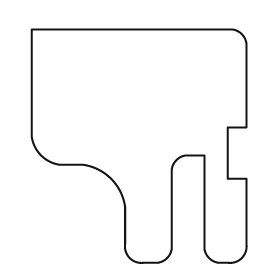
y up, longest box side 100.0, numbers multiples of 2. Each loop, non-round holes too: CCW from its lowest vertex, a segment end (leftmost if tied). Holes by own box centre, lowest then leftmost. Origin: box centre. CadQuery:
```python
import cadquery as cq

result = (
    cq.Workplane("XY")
    .moveTo(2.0, -50.0)
    .lineTo(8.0, -50.0)
    .threePointArc((12.0, -48.0), (14.0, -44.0))
    .lineTo(14.0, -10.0)
    .threePointArc((16.0, -6.0), (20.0, -4.0))
    .lineTo(28.0, -4.0)
    .lineTo(28.0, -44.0)
    .threePointArc((30.0, -48.0), (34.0, -50.0))
    .lineTo(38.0, -50.0)
    .threePointArc((44.0, -48.0), (46.0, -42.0))
    .lineTo(46.0, -14.0)
    .lineTo(38.0, -14.0)
    .lineTo(38.0, 8.0)
    .lineTo(46.0, 8.0)
    .lineTo(46.0, 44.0)
    .threePointArc((44.0, 48.0), (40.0, 50.0))
    .lineTo(-46.0, 50.0)
    .lineTo(-46.0, 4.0)
    .threePointArc((-42.0, -4.0), (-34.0, -8.0))
    .lineTo(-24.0, -8.0)
    .threePointArc((-12.0, -14.0), (-6.0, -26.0))
    .lineTo(-6.0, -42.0)
    .threePointArc((-4.0, -48.0), (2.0, -50.0))
    .close()
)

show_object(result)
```